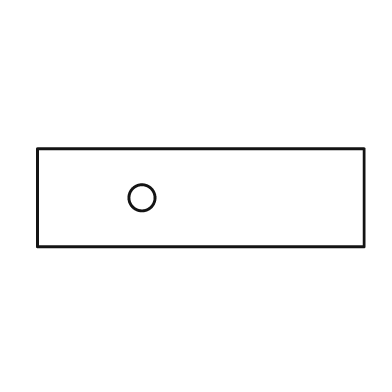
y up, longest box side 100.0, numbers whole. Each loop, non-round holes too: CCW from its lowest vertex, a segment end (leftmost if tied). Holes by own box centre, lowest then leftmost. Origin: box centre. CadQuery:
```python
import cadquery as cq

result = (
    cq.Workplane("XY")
    .moveTo(-50.0, -15.0)
    .lineTo(50.0, -15.0)
    .lineTo(50.0, 15.0)
    .lineTo(-50.0, 15.0)
    .close()
    .moveTo(-18.0, 0.0)
    .circle(4.0)
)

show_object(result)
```